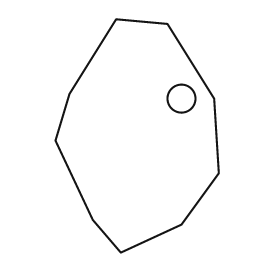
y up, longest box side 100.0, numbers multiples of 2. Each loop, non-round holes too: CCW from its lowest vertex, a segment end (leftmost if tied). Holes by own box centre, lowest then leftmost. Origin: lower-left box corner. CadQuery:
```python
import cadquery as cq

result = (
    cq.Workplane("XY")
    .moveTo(28.0, 0.0)
    .lineTo(54.0, 12.0)
    .lineTo(70.0, 34.0)
    .lineTo(68.0, 66.0)
    .lineTo(48.0, 98.0)
    .lineTo(26.0, 100.0)
    .lineTo(6.0, 68.0)
    .lineTo(0.0, 48.0)
    .lineTo(16.0, 14.0)
    .close()
    .moveTo(54.0, 66.0)
    .circle(6.0)
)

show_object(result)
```